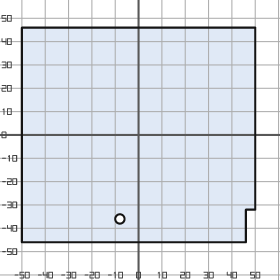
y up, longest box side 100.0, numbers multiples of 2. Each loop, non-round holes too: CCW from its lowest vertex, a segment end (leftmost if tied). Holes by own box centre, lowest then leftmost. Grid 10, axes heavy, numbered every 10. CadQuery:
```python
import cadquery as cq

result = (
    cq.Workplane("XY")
    .moveTo(-50.0, -46.0)
    .lineTo(46.0, -46.0)
    .lineTo(46.0, -32.0)
    .lineTo(50.0, -32.0)
    .lineTo(50.0, 46.0)
    .lineTo(-50.0, 46.0)
    .close()
    .moveTo(-8.0, -36.0)
    .circle(2.0)
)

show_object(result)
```